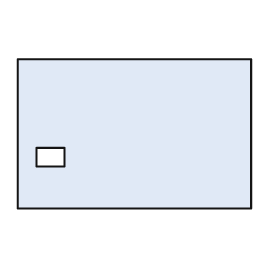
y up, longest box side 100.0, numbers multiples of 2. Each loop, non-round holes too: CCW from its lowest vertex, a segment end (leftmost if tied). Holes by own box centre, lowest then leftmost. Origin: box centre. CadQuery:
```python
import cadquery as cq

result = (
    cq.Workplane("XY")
    .moveTo(-50.0, -32.0)
    .lineTo(50.0, -32.0)
    .lineTo(50.0, 32.0)
    .lineTo(-50.0, 32.0)
    .close()
    .moveTo(-42.0, -14.0)
    .lineTo(-30.0, -14.0)
    .lineTo(-30.0, -6.0)
    .lineTo(-42.0, -6.0)
    .close()
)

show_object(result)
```